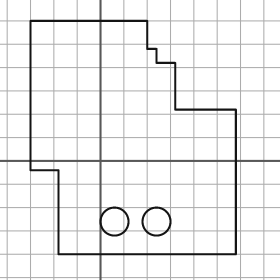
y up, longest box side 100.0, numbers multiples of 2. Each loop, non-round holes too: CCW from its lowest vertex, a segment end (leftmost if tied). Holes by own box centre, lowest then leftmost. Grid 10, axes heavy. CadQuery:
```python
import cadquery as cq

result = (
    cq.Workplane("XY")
    .moveTo(-18.0, -40.0)
    .lineTo(58.0, -40.0)
    .lineTo(58.0, 22.0)
    .lineTo(32.0, 22.0)
    .lineTo(32.0, 42.0)
    .lineTo(24.0, 42.0)
    .lineTo(24.0, 48.0)
    .lineTo(20.0, 48.0)
    .lineTo(20.0, 60.0)
    .lineTo(-30.0, 60.0)
    .lineTo(-30.0, -4.0)
    .lineTo(-18.0, -4.0)
    .close()
    .moveTo(6.0, -26.0)
    .circle(6.0)
    .moveTo(24.0, -26.0)
    .circle(6.0)
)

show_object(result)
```